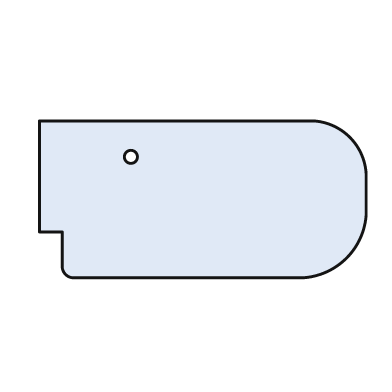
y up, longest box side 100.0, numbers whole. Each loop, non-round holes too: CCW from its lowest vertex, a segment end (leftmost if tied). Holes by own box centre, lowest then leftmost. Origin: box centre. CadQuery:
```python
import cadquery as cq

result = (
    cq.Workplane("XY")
    .moveTo(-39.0, -24.0)
    .lineTo(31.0, -24.0)
    .threePointArc((44.0, -18.0), (50.0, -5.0))
    .lineTo(50.0, 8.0)
    .threePointArc((45.0, 19.0), (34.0, 24.0))
    .lineTo(-50.0, 24.0)
    .lineTo(-50.0, -10.0)
    .lineTo(-43.0, -10.0)
    .lineTo(-43.0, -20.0)
    .threePointArc((-42.0, -23.0), (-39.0, -24.0))
    .close()
    .moveTo(-22.0, 13.0)
    .circle(2.0)
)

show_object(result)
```